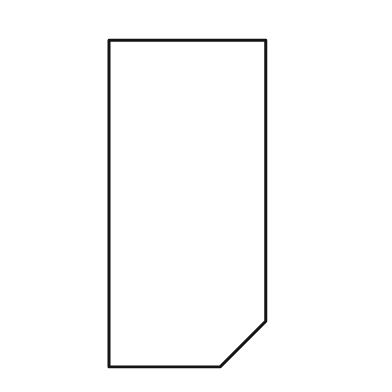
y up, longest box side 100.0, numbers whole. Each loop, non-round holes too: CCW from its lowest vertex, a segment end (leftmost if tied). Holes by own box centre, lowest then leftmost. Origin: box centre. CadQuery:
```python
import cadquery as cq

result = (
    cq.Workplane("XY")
    .moveTo(-24.0, -50.0)
    .lineTo(10.0, -50.0)
    .lineTo(24.0, -36.0)
    .lineTo(24.0, 50.0)
    .lineTo(-24.0, 50.0)
    .close()
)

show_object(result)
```